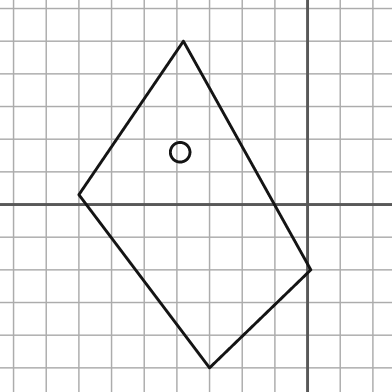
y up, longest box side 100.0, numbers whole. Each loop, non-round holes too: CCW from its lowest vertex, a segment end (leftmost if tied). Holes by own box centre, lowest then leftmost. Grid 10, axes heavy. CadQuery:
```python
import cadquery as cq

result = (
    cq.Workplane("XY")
    .moveTo(-30.0, -50.0)
    .lineTo(1.0, -20.0)
    .lineTo(-38.0, 50.0)
    .lineTo(-70.0, 3.0)
    .close()
    .moveTo(-39.0, 16.0)
    .circle(3.0)
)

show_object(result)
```